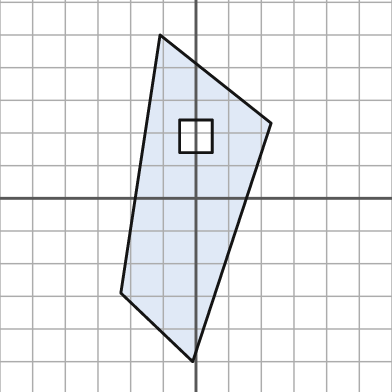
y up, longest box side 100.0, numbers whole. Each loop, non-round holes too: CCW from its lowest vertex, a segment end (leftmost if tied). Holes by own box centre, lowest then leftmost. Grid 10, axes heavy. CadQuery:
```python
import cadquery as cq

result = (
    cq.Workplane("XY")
    .moveTo(-1.0, -50.0)
    .lineTo(23.0, 23.0)
    .lineTo(-11.0, 50.0)
    .lineTo(-23.0, -29.0)
    .close()
    .moveTo(-5.0, 14.0)
    .lineTo(5.0, 14.0)
    .lineTo(5.0, 24.0)
    .lineTo(-5.0, 24.0)
    .close()
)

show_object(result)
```